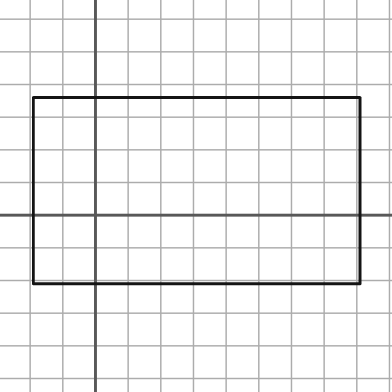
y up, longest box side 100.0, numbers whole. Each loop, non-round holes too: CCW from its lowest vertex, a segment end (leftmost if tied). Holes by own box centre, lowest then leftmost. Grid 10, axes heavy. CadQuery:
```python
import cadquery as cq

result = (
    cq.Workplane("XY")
    .moveTo(-19.0, -21.0)
    .lineTo(81.0, -21.0)
    .lineTo(81.0, 36.0)
    .lineTo(-19.0, 36.0)
    .close()
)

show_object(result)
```